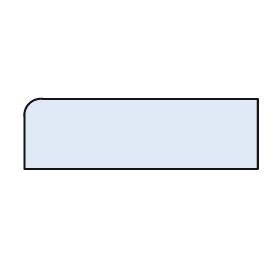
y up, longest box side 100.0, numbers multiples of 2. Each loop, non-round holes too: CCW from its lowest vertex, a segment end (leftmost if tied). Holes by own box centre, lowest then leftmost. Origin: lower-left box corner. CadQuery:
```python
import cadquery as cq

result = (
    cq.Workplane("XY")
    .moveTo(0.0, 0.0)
    .lineTo(100.0, 0.0)
    .lineTo(100.0, 30.0)
    .lineTo(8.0, 30.0)
    .threePointArc((2.0, 28.0), (0.0, 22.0))
    .close()
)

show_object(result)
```